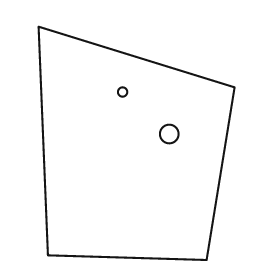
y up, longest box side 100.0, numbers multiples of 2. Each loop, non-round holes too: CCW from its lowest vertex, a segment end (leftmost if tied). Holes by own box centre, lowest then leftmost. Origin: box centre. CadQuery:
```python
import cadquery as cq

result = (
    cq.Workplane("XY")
    .moveTo(30.0, -50.0)
    .lineTo(42.0, 24.0)
    .lineTo(-42.0, 50.0)
    .lineTo(-38.0, -48.0)
    .close()
    .moveTo(14.0, 4.0)
    .circle(4.0)
    .moveTo(-6.0, 22.0)
    .circle(2.0)
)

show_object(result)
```